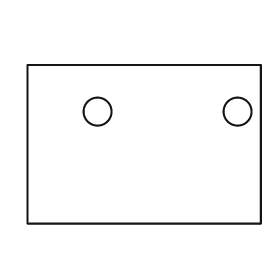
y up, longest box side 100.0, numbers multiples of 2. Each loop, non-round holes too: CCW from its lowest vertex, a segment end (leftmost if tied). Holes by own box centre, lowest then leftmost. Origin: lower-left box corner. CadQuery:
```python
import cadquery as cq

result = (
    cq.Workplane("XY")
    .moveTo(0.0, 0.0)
    .lineTo(100.0, 0.0)
    .lineTo(100.0, 68.0)
    .lineTo(0.0, 68.0)
    .close()
    .moveTo(30.0, 48.0)
    .circle(6.0)
    .moveTo(90.0, 48.0)
    .circle(6.0)
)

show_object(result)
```